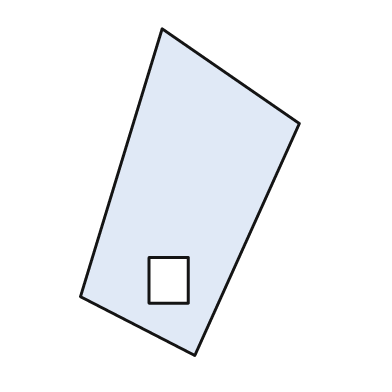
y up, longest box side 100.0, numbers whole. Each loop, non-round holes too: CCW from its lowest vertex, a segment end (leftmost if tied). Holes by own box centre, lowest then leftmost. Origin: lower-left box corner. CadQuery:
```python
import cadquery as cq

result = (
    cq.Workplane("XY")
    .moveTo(35.0, 0.0)
    .lineTo(67.0, 71.0)
    .lineTo(25.0, 100.0)
    .lineTo(0.0, 18.0)
    .close()
    .moveTo(21.0, 16.0)
    .lineTo(33.0, 16.0)
    .lineTo(33.0, 30.0)
    .lineTo(21.0, 30.0)
    .close()
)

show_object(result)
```